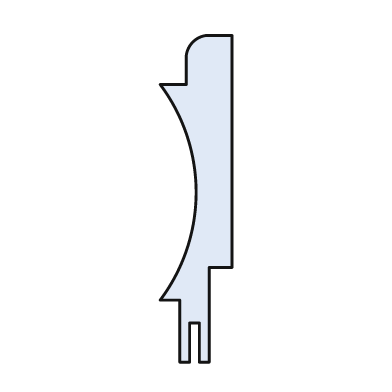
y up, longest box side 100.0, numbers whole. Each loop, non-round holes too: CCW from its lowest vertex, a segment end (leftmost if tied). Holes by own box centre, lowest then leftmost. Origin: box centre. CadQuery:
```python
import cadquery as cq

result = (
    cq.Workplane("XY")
    .moveTo(-5.0, -50.0)
    .lineTo(-2.0, -50.0)
    .lineTo(-2.0, -38.0)
    .lineTo(1.0, -38.0)
    .lineTo(1.0, -50.0)
    .lineTo(4.0, -50.0)
    .lineTo(4.0, -21.0)
    .lineTo(11.0, -21.0)
    .lineTo(11.0, 50.0)
    .lineTo(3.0, 50.0)
    .threePointArc((-1.0, 48.0), (-3.0, 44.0))
    .lineTo(-3.0, 35.0)
    .lineTo(-11.0, 35.0)
    .threePointArc((0.0, 2.0), (-11.0, -31.0))
    .lineTo(-5.0, -31.0)
    .close()
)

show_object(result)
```